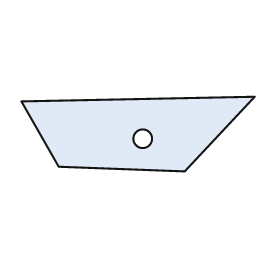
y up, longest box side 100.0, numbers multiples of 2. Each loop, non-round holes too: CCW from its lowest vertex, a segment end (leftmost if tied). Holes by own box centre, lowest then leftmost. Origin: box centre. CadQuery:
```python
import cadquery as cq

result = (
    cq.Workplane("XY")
    .moveTo(20.0, -16.0)
    .lineTo(50.0, 16.0)
    .lineTo(-50.0, 14.0)
    .lineTo(-34.0, -14.0)
    .close()
    .moveTo(2.0, -2.0)
    .circle(4.0)
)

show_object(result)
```